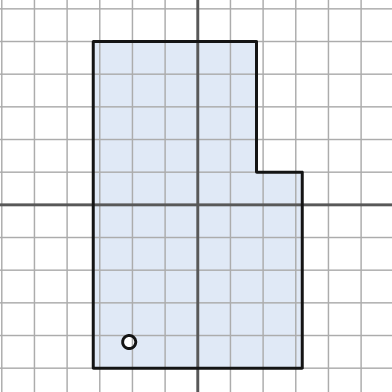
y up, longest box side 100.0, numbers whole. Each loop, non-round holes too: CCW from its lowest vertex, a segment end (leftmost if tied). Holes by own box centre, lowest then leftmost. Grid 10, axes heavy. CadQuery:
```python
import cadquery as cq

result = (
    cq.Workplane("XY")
    .moveTo(-32.0, -50.0)
    .lineTo(32.0, -50.0)
    .lineTo(32.0, 10.0)
    .lineTo(18.0, 10.0)
    .lineTo(18.0, 50.0)
    .lineTo(-32.0, 50.0)
    .close()
    .moveTo(-21.0, -42.0)
    .circle(2.0)
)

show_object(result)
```